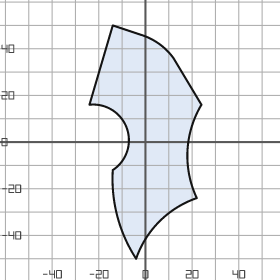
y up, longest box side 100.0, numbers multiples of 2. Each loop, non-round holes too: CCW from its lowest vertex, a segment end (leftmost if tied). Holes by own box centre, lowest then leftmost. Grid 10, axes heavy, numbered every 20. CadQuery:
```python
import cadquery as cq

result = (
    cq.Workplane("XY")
    .moveTo(-4.0, -50.0)
    .threePointArc((6.0, -34.0), (22.0, -24.0))
    .threePointArc((18.0, -4.0), (24.0, 16.0))
    .lineTo(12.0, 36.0)
    .threePointArc((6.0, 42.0), (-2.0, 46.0))
    .lineTo(-14.0, 50.0)
    .lineTo(-24.0, 16.0)
    .threePointArc((-8.0, 6.0), (-14.0, -12.0))
    .threePointArc((-12.0, -32.0), (-4.0, -50.0))
    .close()
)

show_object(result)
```